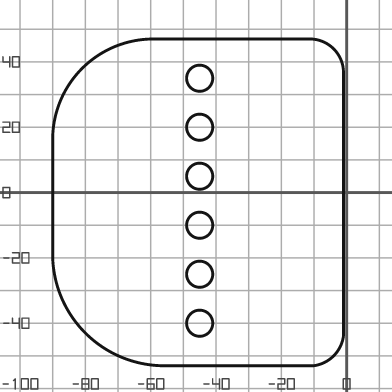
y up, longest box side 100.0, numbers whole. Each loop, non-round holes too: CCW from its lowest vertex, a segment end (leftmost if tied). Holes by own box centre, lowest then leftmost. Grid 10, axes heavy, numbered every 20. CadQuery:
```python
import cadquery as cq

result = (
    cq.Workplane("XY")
    .moveTo(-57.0, -53.0)
    .lineTo(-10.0, -53.0)
    .threePointArc((-4.0, -50.0), (-1.0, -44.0))
    .lineTo(-1.0, 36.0)
    .threePointArc((-4.0, 44.0), (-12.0, 47.0))
    .lineTo(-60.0, 47.0)
    .threePointArc((-81.0, 38.0), (-90.0, 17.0))
    .lineTo(-90.0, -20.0)
    .threePointArc((-80.0, -43.0), (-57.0, -53.0))
    .close()
    .moveTo(-45.0, -40.0)
    .circle(4.0)
    .moveTo(-45.0, -25.0)
    .circle(4.0)
    .moveTo(-45.0, -10.0)
    .circle(4.0)
    .moveTo(-45.0, 5.0)
    .circle(4.0)
    .moveTo(-45.0, 20.0)
    .circle(4.0)
    .moveTo(-45.0, 35.0)
    .circle(4.0)
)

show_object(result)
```